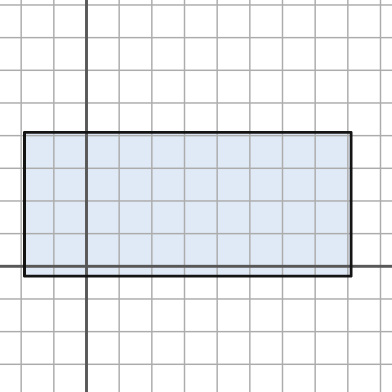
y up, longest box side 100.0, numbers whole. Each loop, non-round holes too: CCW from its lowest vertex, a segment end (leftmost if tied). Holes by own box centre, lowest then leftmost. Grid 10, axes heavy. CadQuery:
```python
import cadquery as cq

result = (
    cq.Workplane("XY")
    .moveTo(-19.0, -3.0)
    .lineTo(81.0, -3.0)
    .lineTo(81.0, 41.0)
    .lineTo(-19.0, 41.0)
    .close()
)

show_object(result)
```